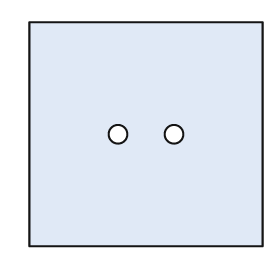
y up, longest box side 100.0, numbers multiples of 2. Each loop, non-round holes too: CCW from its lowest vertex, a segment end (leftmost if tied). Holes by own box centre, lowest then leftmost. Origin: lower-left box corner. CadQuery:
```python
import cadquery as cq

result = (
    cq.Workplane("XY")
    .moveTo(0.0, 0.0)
    .lineTo(100.0, 0.0)
    .lineTo(100.0, 96.0)
    .lineTo(0.0, 96.0)
    .close()
    .moveTo(38.0, 48.0)
    .circle(4.0)
    .moveTo(62.0, 48.0)
    .circle(4.0)
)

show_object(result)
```